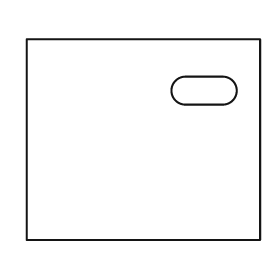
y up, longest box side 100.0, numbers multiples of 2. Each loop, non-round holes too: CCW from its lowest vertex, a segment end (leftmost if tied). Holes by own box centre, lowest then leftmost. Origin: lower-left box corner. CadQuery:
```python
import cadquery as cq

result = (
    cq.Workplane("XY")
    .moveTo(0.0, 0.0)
    .lineTo(100.0, 0.0)
    .lineTo(100.0, 86.0)
    .lineTo(0.0, 86.0)
    .close()
    .moveTo(68.0, 58.0)
    .lineTo(84.0, 58.0)
    .threePointArc((90.0, 64.0), (84.0, 70.0))
    .lineTo(68.0, 70.0)
    .threePointArc((62.0, 64.0), (68.0, 58.0))
    .close()
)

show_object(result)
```